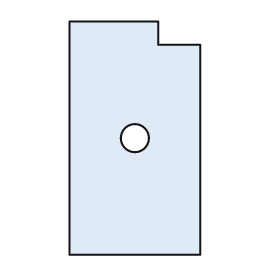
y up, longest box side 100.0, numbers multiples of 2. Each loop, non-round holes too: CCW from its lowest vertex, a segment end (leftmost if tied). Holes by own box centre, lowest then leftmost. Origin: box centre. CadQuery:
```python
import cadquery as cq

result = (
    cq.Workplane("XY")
    .moveTo(-28.0, -50.0)
    .lineTo(28.0, -50.0)
    .lineTo(28.0, 40.0)
    .lineTo(10.0, 40.0)
    .lineTo(10.0, 50.0)
    .lineTo(-28.0, 50.0)
    .close()
    .moveTo(0.0, 0.0)
    .circle(6.0)
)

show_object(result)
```